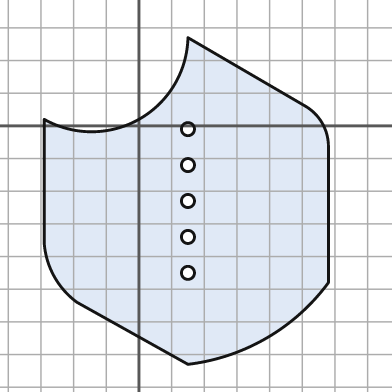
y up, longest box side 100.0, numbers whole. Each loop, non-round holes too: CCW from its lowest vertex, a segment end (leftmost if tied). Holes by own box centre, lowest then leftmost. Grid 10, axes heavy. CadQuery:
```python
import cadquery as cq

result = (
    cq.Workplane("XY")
    .moveTo(15.0, -73.0)
    .threePointArc((39.0, -65.0), (58.0, -48.0))
    .lineTo(58.0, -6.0)
    .threePointArc((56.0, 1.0), (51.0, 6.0))
    .lineTo(15.0, 27.0)
    .threePointArc((0.0, 2.0), (-29.0, 2.0))
    .lineTo(-29.0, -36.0)
    .threePointArc((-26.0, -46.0), (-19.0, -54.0))
    .close()
    .moveTo(15.0, -45.0)
    .circle(2.0)
    .moveTo(15.0, -34.0)
    .circle(2.0)
    .moveTo(15.0, -23.0)
    .circle(2.0)
    .moveTo(15.0, -12.0)
    .circle(2.0)
    .moveTo(15.0, -1.0)
    .circle(2.0)
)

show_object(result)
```